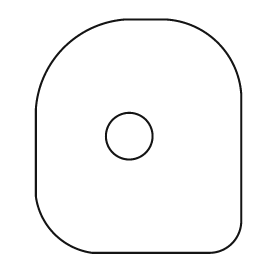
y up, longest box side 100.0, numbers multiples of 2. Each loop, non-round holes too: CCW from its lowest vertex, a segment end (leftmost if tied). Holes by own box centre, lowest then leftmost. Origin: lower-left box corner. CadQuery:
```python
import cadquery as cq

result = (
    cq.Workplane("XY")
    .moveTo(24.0, 0.0)
    .lineTo(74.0, 0.0)
    .threePointArc((84.0, 4.0), (88.0, 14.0))
    .lineTo(88.0, 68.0)
    .threePointArc((78.0, 90.0), (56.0, 100.0))
    .lineTo(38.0, 100.0)
    .threePointArc((12.0, 88.0), (0.0, 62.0))
    .lineTo(0.0, 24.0)
    .threePointArc((8.0, 8.0), (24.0, 0.0))
    .close()
    .moveTo(40.0, 50.0)
    .circle(10.0)
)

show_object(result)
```